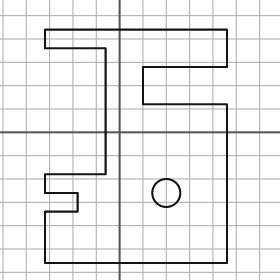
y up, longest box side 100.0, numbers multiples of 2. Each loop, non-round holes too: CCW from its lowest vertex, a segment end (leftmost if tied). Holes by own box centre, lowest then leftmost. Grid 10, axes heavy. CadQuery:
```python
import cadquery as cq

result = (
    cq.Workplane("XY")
    .moveTo(-32.0, -56.0)
    .lineTo(46.0, -56.0)
    .lineTo(46.0, 12.0)
    .lineTo(10.0, 12.0)
    .lineTo(10.0, 28.0)
    .lineTo(46.0, 28.0)
    .lineTo(46.0, 44.0)
    .lineTo(-32.0, 44.0)
    .lineTo(-32.0, 36.0)
    .lineTo(-6.0, 36.0)
    .lineTo(-6.0, -18.0)
    .lineTo(-32.0, -18.0)
    .lineTo(-32.0, -26.0)
    .lineTo(-18.0, -26.0)
    .lineTo(-18.0, -34.0)
    .lineTo(-32.0, -34.0)
    .close()
    .moveTo(20.0, -26.0)
    .circle(6.0)
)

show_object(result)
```